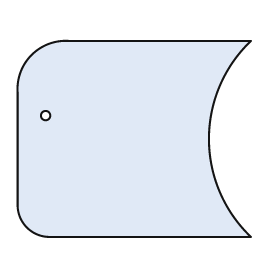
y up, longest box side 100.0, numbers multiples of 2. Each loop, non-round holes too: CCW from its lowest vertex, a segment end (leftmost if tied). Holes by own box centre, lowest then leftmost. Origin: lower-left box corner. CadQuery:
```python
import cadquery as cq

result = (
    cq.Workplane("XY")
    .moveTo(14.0, 0.0)
    .lineTo(100.0, 0.0)
    .threePointArc((82.0, 42.0), (100.0, 84.0))
    .lineTo(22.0, 84.0)
    .threePointArc((6.0, 78.0), (0.0, 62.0))
    .lineTo(0.0, 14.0)
    .threePointArc((4.0, 4.0), (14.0, 0.0))
    .close()
    .moveTo(12.0, 52.0)
    .circle(2.0)
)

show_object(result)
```